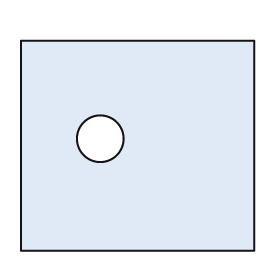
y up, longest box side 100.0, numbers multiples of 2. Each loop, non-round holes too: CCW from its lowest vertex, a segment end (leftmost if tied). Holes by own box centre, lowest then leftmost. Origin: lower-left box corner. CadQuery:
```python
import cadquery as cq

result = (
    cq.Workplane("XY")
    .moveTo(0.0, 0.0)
    .lineTo(100.0, 0.0)
    .lineTo(100.0, 90.0)
    .lineTo(0.0, 90.0)
    .close()
    .moveTo(34.0, 48.0)
    .circle(10.0)
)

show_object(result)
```